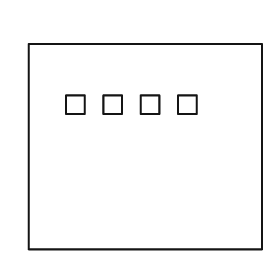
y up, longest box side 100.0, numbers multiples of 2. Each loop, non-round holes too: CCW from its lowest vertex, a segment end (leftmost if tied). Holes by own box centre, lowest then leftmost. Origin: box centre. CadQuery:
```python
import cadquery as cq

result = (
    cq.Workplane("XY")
    .moveTo(-50.0, -44.0)
    .lineTo(50.0, -44.0)
    .lineTo(50.0, 44.0)
    .lineTo(-50.0, 44.0)
    .close()
    .moveTo(-34.0, 14.0)
    .lineTo(-26.0, 14.0)
    .lineTo(-26.0, 22.0)
    .lineTo(-34.0, 22.0)
    .close()
    .moveTo(-18.0, 14.0)
    .lineTo(-10.0, 14.0)
    .lineTo(-10.0, 22.0)
    .lineTo(-18.0, 22.0)
    .close()
    .moveTo(-2.0, 14.0)
    .lineTo(6.0, 14.0)
    .lineTo(6.0, 22.0)
    .lineTo(-2.0, 22.0)
    .close()
    .moveTo(14.0, 14.0)
    .lineTo(22.0, 14.0)
    .lineTo(22.0, 22.0)
    .lineTo(14.0, 22.0)
    .close()
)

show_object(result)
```